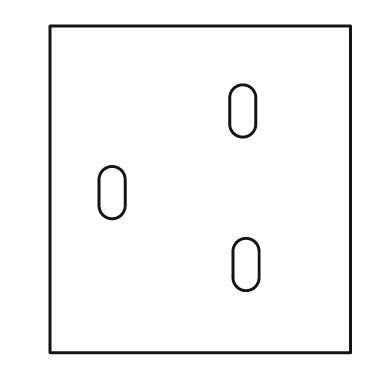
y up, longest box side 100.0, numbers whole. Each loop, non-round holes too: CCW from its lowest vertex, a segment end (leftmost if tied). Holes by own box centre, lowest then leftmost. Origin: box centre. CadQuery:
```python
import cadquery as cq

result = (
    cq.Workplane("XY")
    .moveTo(-46.0, -50.0)
    .lineTo(46.0, -50.0)
    .lineTo(46.0, 50.0)
    .lineTo(-46.0, 50.0)
    .close()
    .moveTo(10.0, -27.0)
    .threePointArc((14.0, -31.0), (18.0, -27.0))
    .lineTo(18.0, -19.0)
    .threePointArc((14.0, -15.0), (10.0, -19.0))
    .close()
    .moveTo(-31.0, -5.0)
    .threePointArc((-27.0, -9.0), (-23.0, -5.0))
    .lineTo(-23.0, 3.0)
    .threePointArc((-27.0, 7.0), (-31.0, 3.0))
    .close()
    .moveTo(9.0, 20.0)
    .threePointArc((13.0, 16.0), (17.0, 20.0))
    .lineTo(17.0, 28.0)
    .threePointArc((13.0, 32.0), (9.0, 28.0))
    .close()
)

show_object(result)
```